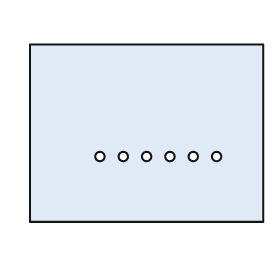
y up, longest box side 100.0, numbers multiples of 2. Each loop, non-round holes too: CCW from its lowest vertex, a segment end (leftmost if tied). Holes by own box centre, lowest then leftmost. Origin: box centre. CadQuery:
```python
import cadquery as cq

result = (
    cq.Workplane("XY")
    .moveTo(-50.0, -38.0)
    .lineTo(50.0, -38.0)
    .lineTo(50.0, 38.0)
    .lineTo(-50.0, 38.0)
    .close()
    .moveTo(-20.0, -10.0)
    .circle(2.0)
    .moveTo(-10.0, -10.0)
    .circle(2.0)
    .moveTo(0.0, -10.0)
    .circle(2.0)
    .moveTo(10.0, -10.0)
    .circle(2.0)
    .moveTo(20.0, -10.0)
    .circle(2.0)
    .moveTo(30.0, -10.0)
    .circle(2.0)
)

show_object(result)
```